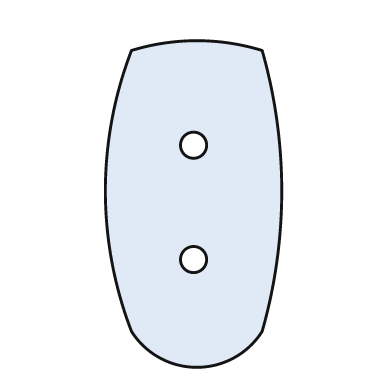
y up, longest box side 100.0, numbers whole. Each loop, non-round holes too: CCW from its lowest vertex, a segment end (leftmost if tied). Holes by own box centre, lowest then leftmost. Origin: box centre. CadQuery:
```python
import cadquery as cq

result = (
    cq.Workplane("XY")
    .moveTo(-19.0, -39.0)
    .threePointArc((1.0, -50.0), (21.0, -39.0))
    .threePointArc((27.0, 4.0), (21.0, 47.0))
    .threePointArc((1.0, 50.0), (-19.0, 47.0))
    .threePointArc((-27.0, 4.0), (-19.0, -39.0))
    .close()
    .moveTo(0.0, -17.0)
    .circle(4.0)
    .moveTo(0.0, 18.0)
    .circle(4.0)
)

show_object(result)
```